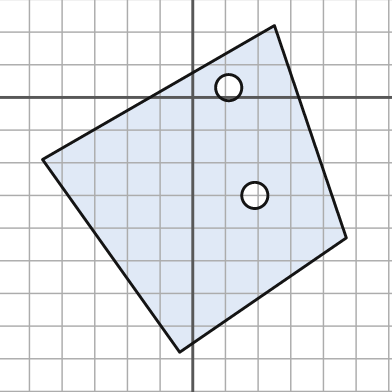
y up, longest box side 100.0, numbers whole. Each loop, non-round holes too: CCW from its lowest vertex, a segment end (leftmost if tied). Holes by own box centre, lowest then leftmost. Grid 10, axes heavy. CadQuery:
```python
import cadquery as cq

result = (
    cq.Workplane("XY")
    .moveTo(-4.0, -78.0)
    .lineTo(47.0, -43.0)
    .lineTo(25.0, 22.0)
    .lineTo(-46.0, -19.0)
    .close()
    .moveTo(19.0, -30.0)
    .circle(4.0)
    .moveTo(11.0, 3.0)
    .circle(4.0)
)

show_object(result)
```